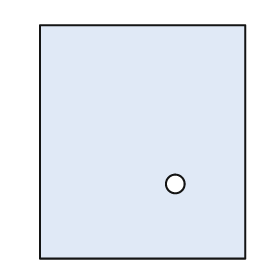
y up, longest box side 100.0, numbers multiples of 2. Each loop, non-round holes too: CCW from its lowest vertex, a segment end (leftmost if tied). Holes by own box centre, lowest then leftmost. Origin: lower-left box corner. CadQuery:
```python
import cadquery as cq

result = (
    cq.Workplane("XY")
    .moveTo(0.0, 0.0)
    .lineTo(88.0, 0.0)
    .lineTo(88.0, 100.0)
    .lineTo(0.0, 100.0)
    .close()
    .moveTo(58.0, 32.0)
    .circle(4.0)
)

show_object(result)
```